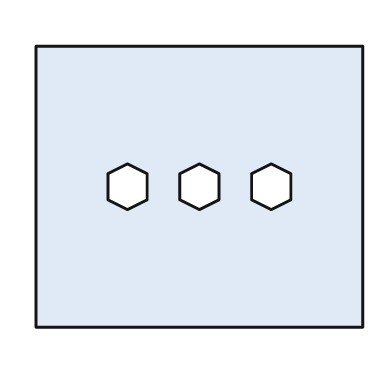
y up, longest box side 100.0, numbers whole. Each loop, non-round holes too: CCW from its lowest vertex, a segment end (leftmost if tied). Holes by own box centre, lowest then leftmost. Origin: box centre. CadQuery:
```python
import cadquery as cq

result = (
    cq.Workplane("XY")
    .moveTo(-50.0, -43.0)
    .lineTo(50.0, -43.0)
    .lineTo(50.0, 43.0)
    .lineTo(-50.0, 43.0)
    .close()
    .moveTo(-22.0, -7.0)
    .lineTo(-16.0, -4.0)
    .lineTo(-16.0, 4.0)
    .lineTo(-22.0, 7.0)
    .lineTo(-28.0, 4.0)
    .lineTo(-28.0, -4.0)
    .close()
    .moveTo(0.0, -7.0)
    .lineTo(6.0, -4.0)
    .lineTo(6.0, 4.0)
    .lineTo(0.0, 7.0)
    .lineTo(-6.0, 4.0)
    .lineTo(-6.0, -4.0)
    .close()
    .moveTo(22.0, -7.0)
    .lineTo(28.0, -4.0)
    .lineTo(28.0, 4.0)
    .lineTo(22.0, 7.0)
    .lineTo(16.0, 4.0)
    .lineTo(16.0, -4.0)
    .close()
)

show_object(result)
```